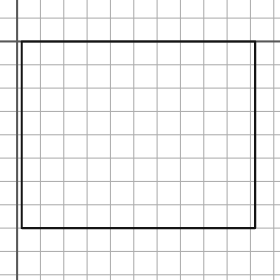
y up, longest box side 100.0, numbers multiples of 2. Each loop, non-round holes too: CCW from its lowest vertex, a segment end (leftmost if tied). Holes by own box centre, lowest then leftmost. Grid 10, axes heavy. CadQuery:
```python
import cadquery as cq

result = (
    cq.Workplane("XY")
    .moveTo(2.0, -80.0)
    .lineTo(102.0, -80.0)
    .lineTo(102.0, 0.0)
    .lineTo(2.0, 0.0)
    .close()
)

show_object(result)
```